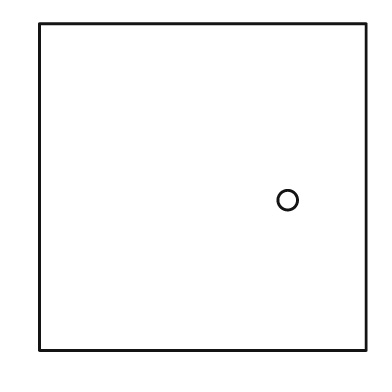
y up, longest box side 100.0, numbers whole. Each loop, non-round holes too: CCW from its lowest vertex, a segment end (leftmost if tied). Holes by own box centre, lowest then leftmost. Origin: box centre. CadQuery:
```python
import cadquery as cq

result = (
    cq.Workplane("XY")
    .moveTo(-50.0, -50.0)
    .lineTo(50.0, -50.0)
    .lineTo(50.0, 50.0)
    .lineTo(-50.0, 50.0)
    .close()
    .moveTo(26.0, -4.0)
    .circle(3.0)
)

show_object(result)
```